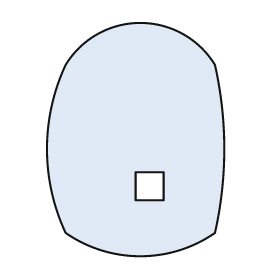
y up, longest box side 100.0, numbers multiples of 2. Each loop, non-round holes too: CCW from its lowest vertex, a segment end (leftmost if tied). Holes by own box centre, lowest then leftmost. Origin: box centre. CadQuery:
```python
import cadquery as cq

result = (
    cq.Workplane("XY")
    .moveTo(-30.0, -40.0)
    .threePointArc((2.0, -50.0), (34.0, -40.0))
    .threePointArc((38.0, -4.0), (34.0, 32.0))
    .threePointArc((2.0, 50.0), (-30.0, 32.0))
    .threePointArc((-38.0, -4.0), (-30.0, -40.0))
    .close()
    .moveTo(0.0, -26.0)
    .lineTo(12.0, -26.0)
    .lineTo(12.0, -14.0)
    .lineTo(0.0, -14.0)
    .close()
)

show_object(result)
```